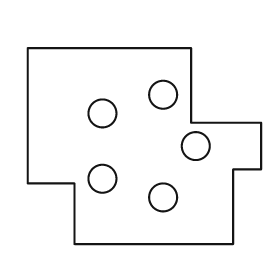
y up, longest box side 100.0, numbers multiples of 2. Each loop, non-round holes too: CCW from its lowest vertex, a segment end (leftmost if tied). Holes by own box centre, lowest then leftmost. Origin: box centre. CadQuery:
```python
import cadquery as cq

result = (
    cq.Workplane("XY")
    .moveTo(-30.0, -42.0)
    .lineTo(38.0, -42.0)
    .lineTo(38.0, -10.0)
    .lineTo(50.0, -10.0)
    .lineTo(50.0, 10.0)
    .lineTo(20.0, 10.0)
    .lineTo(20.0, 42.0)
    .lineTo(-50.0, 42.0)
    .lineTo(-50.0, -16.0)
    .lineTo(-30.0, -16.0)
    .close()
    .moveTo(8.0, -22.0)
    .circle(6.0)
    .moveTo(-18.0, -14.0)
    .circle(6.0)
    .moveTo(22.0, 0.0)
    .circle(6.0)
    .moveTo(-18.0, 14.0)
    .circle(6.0)
    .moveTo(8.0, 22.0)
    .circle(6.0)
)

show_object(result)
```